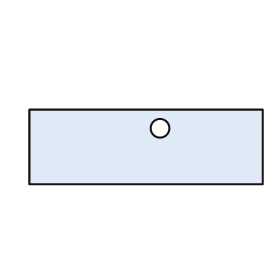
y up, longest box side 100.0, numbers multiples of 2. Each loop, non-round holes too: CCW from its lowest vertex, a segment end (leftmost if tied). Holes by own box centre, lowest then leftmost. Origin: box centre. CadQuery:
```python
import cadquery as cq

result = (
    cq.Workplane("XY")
    .moveTo(-50.0, -16.0)
    .lineTo(50.0, -16.0)
    .lineTo(50.0, 16.0)
    .lineTo(-50.0, 16.0)
    .close()
    .moveTo(6.0, 8.0)
    .circle(4.0)
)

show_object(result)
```